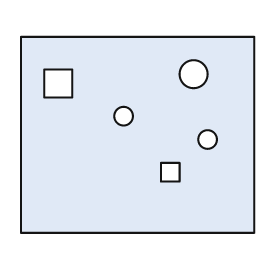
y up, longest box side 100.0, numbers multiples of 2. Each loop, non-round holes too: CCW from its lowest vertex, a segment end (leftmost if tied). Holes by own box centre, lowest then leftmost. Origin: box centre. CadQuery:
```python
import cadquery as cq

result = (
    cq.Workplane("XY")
    .moveTo(-50.0, -42.0)
    .lineTo(50.0, -42.0)
    .lineTo(50.0, 42.0)
    .lineTo(-50.0, 42.0)
    .close()
    .moveTo(10.0, -20.0)
    .lineTo(18.0, -20.0)
    .lineTo(18.0, -12.0)
    .lineTo(10.0, -12.0)
    .close()
    .moveTo(30.0, -2.0)
    .circle(4.0)
    .moveTo(-6.0, 8.0)
    .circle(4.0)
    .moveTo(-40.0, 16.0)
    .lineTo(-28.0, 16.0)
    .lineTo(-28.0, 28.0)
    .lineTo(-40.0, 28.0)
    .close()
    .moveTo(24.0, 26.0)
    .circle(6.0)
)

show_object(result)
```